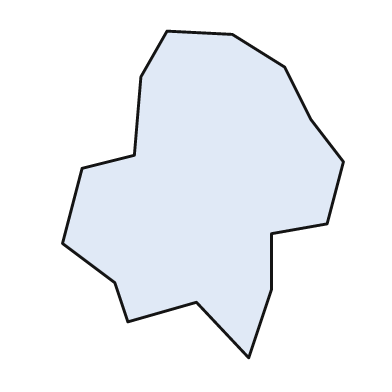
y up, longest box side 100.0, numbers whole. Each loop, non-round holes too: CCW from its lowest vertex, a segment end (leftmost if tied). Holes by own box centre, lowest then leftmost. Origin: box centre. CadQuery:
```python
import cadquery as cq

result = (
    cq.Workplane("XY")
    .moveTo(14.0, -50.0)
    .lineTo(21.0, -29.0)
    .lineTo(21.0, -12.0)
    .lineTo(38.0, -9.0)
    .lineTo(43.0, 10.0)
    .lineTo(33.0, 23.0)
    .lineTo(25.0, 39.0)
    .lineTo(9.0, 49.0)
    .lineTo(-11.0, 50.0)
    .lineTo(-19.0, 36.0)
    .lineTo(-21.0, 12.0)
    .lineTo(-37.0, 8.0)
    .lineTo(-43.0, -15.0)
    .lineTo(-27.0, -27.0)
    .lineTo(-23.0, -39.0)
    .lineTo(-2.0, -33.0)
    .close()
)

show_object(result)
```